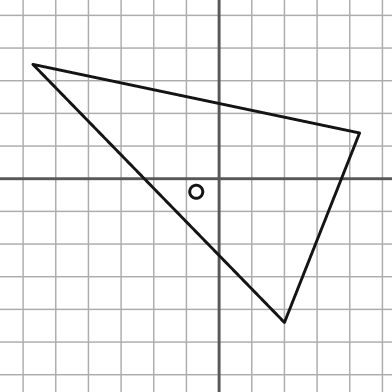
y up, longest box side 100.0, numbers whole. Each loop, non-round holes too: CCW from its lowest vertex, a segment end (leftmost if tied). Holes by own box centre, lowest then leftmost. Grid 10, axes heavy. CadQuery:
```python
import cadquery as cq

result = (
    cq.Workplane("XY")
    .moveTo(20.0, -44.0)
    .lineTo(43.0, 14.0)
    .lineTo(-57.0, 35.0)
    .close()
    .moveTo(-7.0, -4.0)
    .circle(2.0)
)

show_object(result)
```